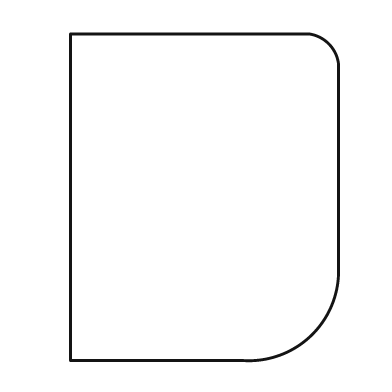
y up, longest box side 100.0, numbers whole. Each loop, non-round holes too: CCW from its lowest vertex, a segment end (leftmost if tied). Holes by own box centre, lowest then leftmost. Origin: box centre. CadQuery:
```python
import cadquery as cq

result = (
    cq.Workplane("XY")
    .moveTo(-41.0, -50.0)
    .lineTo(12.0, -50.0)
    .threePointArc((33.0, -42.0), (41.0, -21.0))
    .lineTo(41.0, 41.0)
    .threePointArc((38.0, 47.0), (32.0, 50.0))
    .lineTo(-41.0, 50.0)
    .close()
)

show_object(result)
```